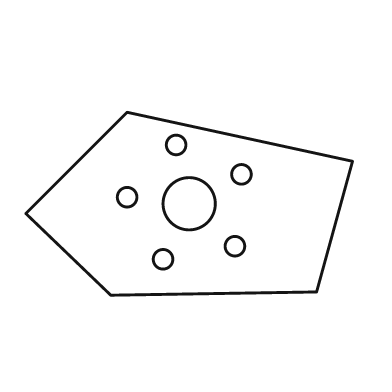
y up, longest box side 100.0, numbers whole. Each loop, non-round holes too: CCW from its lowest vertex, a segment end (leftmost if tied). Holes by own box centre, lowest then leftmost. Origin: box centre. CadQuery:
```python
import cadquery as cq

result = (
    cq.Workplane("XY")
    .moveTo(-24.0, -28.0)
    .lineTo(39.0, -27.0)
    .lineTo(50.0, 13.0)
    .lineTo(-19.0, 28.0)
    .lineTo(-50.0, -3.0)
    .close()
    .moveTo(-8.0, -17.0)
    .circle(3.0)
    .moveTo(14.0, -13.0)
    .circle(3.0)
    .moveTo(0.0, 0.0)
    .circle(8.0)
    .moveTo(-19.0, 2.0)
    .circle(3.0)
    .moveTo(16.0, 9.0)
    .circle(3.0)
    .moveTo(-4.0, 18.0)
    .circle(3.0)
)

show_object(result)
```